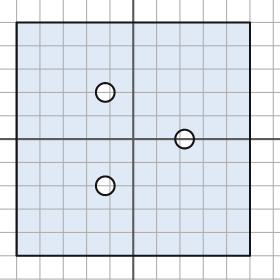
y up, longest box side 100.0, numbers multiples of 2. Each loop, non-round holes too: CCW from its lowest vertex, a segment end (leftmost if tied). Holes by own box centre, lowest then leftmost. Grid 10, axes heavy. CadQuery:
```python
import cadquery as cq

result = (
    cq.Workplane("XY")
    .moveTo(-50.0, -50.0)
    .lineTo(50.0, -50.0)
    .lineTo(50.0, 50.0)
    .lineTo(-50.0, 50.0)
    .close()
    .moveTo(-12.0, -20.0)
    .circle(4.0)
    .moveTo(22.0, 0.0)
    .circle(4.0)
    .moveTo(-12.0, 20.0)
    .circle(4.0)
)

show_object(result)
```